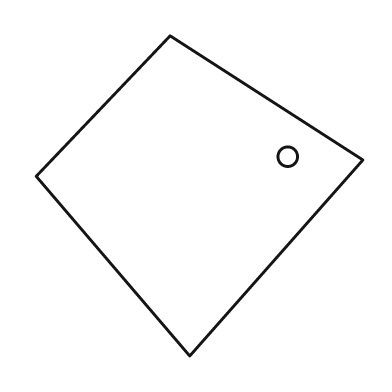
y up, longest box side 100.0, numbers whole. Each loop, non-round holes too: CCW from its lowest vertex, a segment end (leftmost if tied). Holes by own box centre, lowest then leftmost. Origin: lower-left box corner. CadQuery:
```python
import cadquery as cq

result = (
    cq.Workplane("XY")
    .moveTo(47.0, 0.0)
    .lineTo(100.0, 60.0)
    .lineTo(41.0, 98.0)
    .lineTo(0.0, 55.0)
    .close()
    .moveTo(77.0, 61.0)
    .circle(3.0)
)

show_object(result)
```